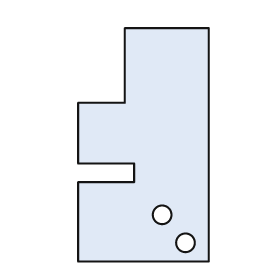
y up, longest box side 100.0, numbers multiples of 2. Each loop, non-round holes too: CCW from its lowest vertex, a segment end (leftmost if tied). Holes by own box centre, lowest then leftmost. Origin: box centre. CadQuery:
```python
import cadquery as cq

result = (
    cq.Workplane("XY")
    .moveTo(-28.0, -50.0)
    .lineTo(28.0, -50.0)
    .lineTo(28.0, 50.0)
    .lineTo(-8.0, 50.0)
    .lineTo(-8.0, 18.0)
    .lineTo(-28.0, 18.0)
    .lineTo(-28.0, -8.0)
    .lineTo(-4.0, -8.0)
    .lineTo(-4.0, -16.0)
    .lineTo(-28.0, -16.0)
    .close()
    .moveTo(18.0, -42.0)
    .circle(4.0)
    .moveTo(8.0, -30.0)
    .circle(4.0)
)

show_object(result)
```